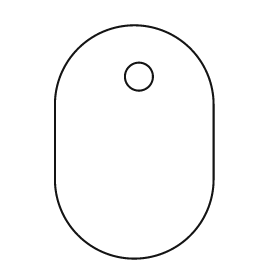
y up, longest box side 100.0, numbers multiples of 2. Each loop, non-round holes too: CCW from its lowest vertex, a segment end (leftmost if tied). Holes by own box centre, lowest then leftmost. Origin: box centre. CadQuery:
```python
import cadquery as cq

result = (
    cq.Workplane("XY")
    .moveTo(-34.0, -16.0)
    .threePointArc((0.0, -50.0), (34.0, -16.0))
    .lineTo(34.0, 16.0)
    .threePointArc((0.0, 50.0), (-34.0, 16.0))
    .close()
    .moveTo(2.0, 28.0)
    .circle(6.0)
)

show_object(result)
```